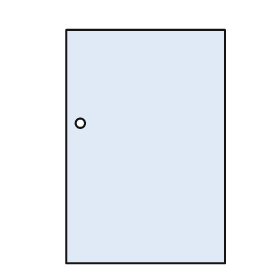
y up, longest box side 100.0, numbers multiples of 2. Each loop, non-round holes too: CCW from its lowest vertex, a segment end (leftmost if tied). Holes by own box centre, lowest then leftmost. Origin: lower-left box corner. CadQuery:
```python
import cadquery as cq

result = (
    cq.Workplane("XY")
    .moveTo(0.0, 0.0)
    .lineTo(68.0, 0.0)
    .lineTo(68.0, 100.0)
    .lineTo(0.0, 100.0)
    .close()
    .moveTo(6.0, 60.0)
    .circle(2.0)
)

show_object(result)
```